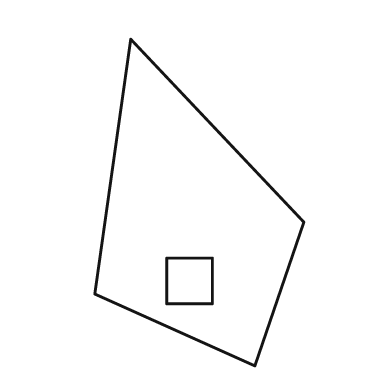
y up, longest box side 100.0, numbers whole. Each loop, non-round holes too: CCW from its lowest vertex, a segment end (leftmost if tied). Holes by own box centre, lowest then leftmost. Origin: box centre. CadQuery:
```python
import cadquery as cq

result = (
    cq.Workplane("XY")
    .moveTo(17.0, -50.0)
    .lineTo(32.0, -6.0)
    .lineTo(-21.0, 50.0)
    .lineTo(-32.0, -28.0)
    .close()
    .moveTo(-10.0, -31.0)
    .lineTo(4.0, -31.0)
    .lineTo(4.0, -17.0)
    .lineTo(-10.0, -17.0)
    .close()
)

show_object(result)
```